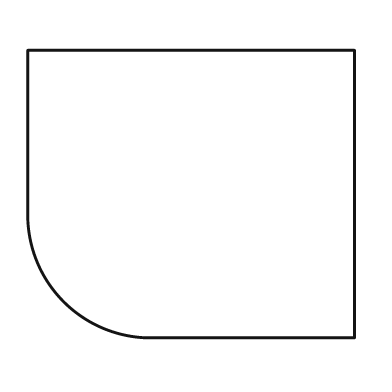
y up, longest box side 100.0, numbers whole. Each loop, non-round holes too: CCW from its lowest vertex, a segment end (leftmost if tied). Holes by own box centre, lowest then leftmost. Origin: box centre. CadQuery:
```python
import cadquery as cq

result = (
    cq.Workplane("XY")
    .moveTo(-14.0, -44.0)
    .lineTo(50.0, -44.0)
    .lineTo(50.0, 44.0)
    .lineTo(-50.0, 44.0)
    .lineTo(-50.0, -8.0)
    .threePointArc((-39.0, -33.0), (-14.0, -44.0))
    .close()
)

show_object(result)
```